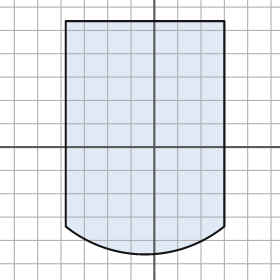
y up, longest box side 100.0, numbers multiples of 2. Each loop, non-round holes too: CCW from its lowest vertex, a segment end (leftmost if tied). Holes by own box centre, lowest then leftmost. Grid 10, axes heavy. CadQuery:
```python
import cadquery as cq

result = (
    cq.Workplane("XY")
    .moveTo(-38.0, -34.0)
    .threePointArc((-4.0, -46.0), (30.0, -34.0))
    .lineTo(30.0, 54.0)
    .lineTo(-38.0, 54.0)
    .close()
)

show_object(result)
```